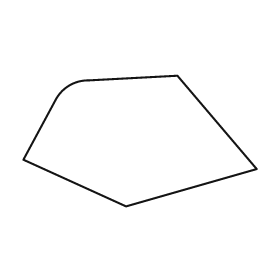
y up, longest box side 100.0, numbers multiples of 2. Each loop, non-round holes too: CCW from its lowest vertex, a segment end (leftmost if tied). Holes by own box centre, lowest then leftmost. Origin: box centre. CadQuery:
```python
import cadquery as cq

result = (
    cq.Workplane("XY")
    .moveTo(-6.0, -28.0)
    .lineTo(50.0, -12.0)
    .lineTo(16.0, 28.0)
    .lineTo(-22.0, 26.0)
    .threePointArc((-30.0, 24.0), (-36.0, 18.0))
    .lineTo(-50.0, -8.0)
    .close()
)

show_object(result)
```